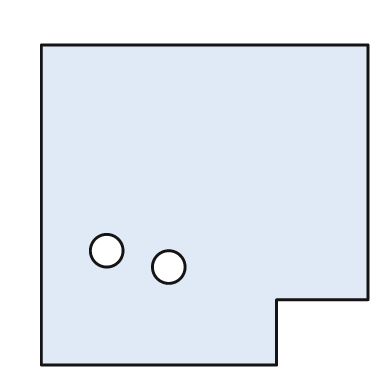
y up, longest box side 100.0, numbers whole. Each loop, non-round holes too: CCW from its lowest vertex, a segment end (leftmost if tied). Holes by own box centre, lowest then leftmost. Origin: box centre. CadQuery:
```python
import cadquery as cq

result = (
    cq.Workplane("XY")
    .moveTo(-50.0, -49.0)
    .lineTo(22.0, -49.0)
    .lineTo(22.0, -29.0)
    .lineTo(50.0, -29.0)
    .lineTo(50.0, 49.0)
    .lineTo(-50.0, 49.0)
    .close()
    .moveTo(-11.0, -19.0)
    .circle(5.0)
    .moveTo(-30.0, -14.0)
    .circle(5.0)
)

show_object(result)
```